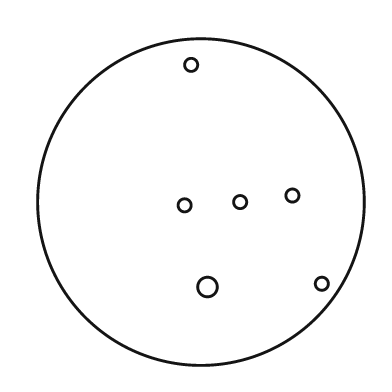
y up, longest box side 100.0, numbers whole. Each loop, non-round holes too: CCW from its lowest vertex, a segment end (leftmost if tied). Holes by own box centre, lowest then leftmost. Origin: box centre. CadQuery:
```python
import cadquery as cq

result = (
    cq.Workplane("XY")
    .moveTo(0.0, 0.0)
    .circle(50.0)
    .moveTo(2.0, -26.0)
    .circle(3.0)
    .moveTo(37.0, -25.0)
    .circle(2.0)
    .moveTo(-5.0, -1.0)
    .circle(2.0)
    .moveTo(12.0, 0.0)
    .circle(2.0)
    .moveTo(28.0, 2.0)
    .circle(2.0)
    .moveTo(-3.0, 42.0)
    .circle(2.0)
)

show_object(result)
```